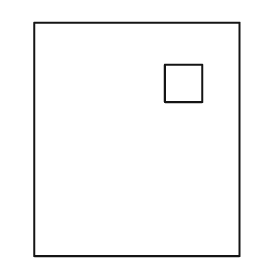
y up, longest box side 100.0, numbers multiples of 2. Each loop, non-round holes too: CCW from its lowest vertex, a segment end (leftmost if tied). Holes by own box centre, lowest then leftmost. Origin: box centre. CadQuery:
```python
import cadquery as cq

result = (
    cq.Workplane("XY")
    .moveTo(-44.0, -50.0)
    .lineTo(44.0, -50.0)
    .lineTo(44.0, 50.0)
    .lineTo(-44.0, 50.0)
    .close()
    .moveTo(12.0, 16.0)
    .lineTo(28.0, 16.0)
    .lineTo(28.0, 32.0)
    .lineTo(12.0, 32.0)
    .close()
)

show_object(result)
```